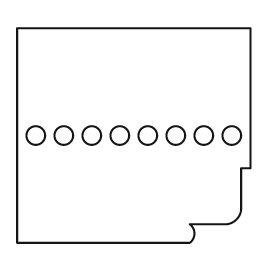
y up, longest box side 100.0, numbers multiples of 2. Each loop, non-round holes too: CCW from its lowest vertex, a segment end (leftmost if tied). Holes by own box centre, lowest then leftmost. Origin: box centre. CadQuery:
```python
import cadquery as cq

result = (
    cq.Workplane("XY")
    .moveTo(-50.0, -46.0)
    .lineTo(24.0, -46.0)
    .threePointArc((26.0, -42.0), (24.0, -38.0))
    .lineTo(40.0, -38.0)
    .threePointArc((44.0, -36.0), (46.0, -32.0))
    .lineTo(46.0, -14.0)
    .lineTo(50.0, -14.0)
    .lineTo(50.0, 46.0)
    .lineTo(-50.0, 46.0)
    .close()
    .moveTo(-42.0, 0.0)
    .circle(4.0)
    .moveTo(-30.0, 0.0)
    .circle(4.0)
    .moveTo(-18.0, 0.0)
    .circle(4.0)
    .moveTo(-6.0, 0.0)
    .circle(4.0)
    .moveTo(6.0, 0.0)
    .circle(4.0)
    .moveTo(18.0, 0.0)
    .circle(4.0)
    .moveTo(30.0, 0.0)
    .circle(4.0)
    .moveTo(42.0, 0.0)
    .circle(4.0)
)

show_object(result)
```